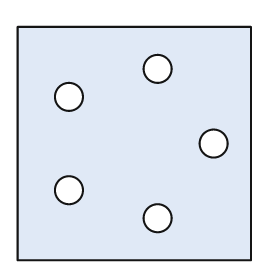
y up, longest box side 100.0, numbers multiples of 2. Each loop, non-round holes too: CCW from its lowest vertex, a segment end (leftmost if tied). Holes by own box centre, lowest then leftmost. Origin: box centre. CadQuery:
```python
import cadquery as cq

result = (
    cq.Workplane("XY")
    .moveTo(-50.0, -50.0)
    .lineTo(50.0, -50.0)
    .lineTo(50.0, 50.0)
    .lineTo(-50.0, 50.0)
    .close()
    .moveTo(10.0, -32.0)
    .circle(6.0)
    .moveTo(-28.0, -20.0)
    .circle(6.0)
    .moveTo(34.0, 0.0)
    .circle(6.0)
    .moveTo(-28.0, 20.0)
    .circle(6.0)
    .moveTo(10.0, 32.0)
    .circle(6.0)
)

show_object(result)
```